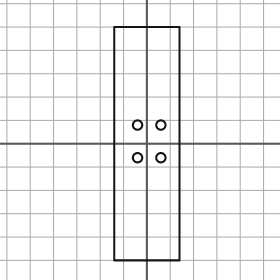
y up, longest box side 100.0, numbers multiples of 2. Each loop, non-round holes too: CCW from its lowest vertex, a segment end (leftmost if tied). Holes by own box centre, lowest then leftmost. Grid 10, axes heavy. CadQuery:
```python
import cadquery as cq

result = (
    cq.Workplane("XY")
    .moveTo(-14.0, -50.0)
    .lineTo(14.0, -50.0)
    .lineTo(14.0, 50.0)
    .lineTo(-14.0, 50.0)
    .close()
    .moveTo(-4.0, -6.0)
    .circle(2.0)
    .moveTo(6.0, -6.0)
    .circle(2.0)
    .moveTo(-4.0, 8.0)
    .circle(2.0)
    .moveTo(6.0, 8.0)
    .circle(2.0)
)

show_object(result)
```